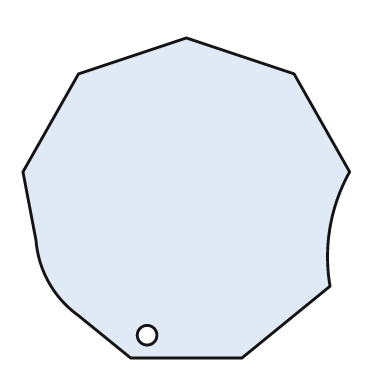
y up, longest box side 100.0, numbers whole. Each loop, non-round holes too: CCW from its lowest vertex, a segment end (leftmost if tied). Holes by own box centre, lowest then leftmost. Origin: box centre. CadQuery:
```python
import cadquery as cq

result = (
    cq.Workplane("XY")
    .moveTo(-17.0, -49.0)
    .lineTo(17.0, -49.0)
    .lineTo(44.0, -27.0)
    .threePointArc((44.0, -9.0), (50.0, 8.0))
    .lineTo(33.0, 38.0)
    .lineTo(0.0, 49.0)
    .lineTo(-33.0, 38.0)
    .lineTo(-50.0, 8.0)
    .lineTo(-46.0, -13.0)
    .threePointArc((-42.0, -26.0), (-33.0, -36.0))
    .close()
    .moveTo(-12.0, -42.0)
    .circle(3.0)
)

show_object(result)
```